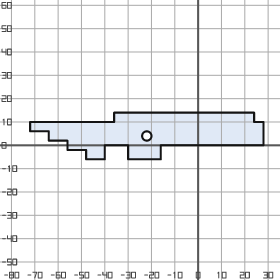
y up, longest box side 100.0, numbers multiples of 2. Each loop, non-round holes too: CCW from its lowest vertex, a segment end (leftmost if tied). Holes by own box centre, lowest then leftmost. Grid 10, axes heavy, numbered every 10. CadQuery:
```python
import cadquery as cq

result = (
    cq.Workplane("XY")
    .moveTo(-48.0, -6.0)
    .lineTo(-40.0, -6.0)
    .lineTo(-40.0, 0.0)
    .lineTo(-30.0, 0.0)
    .lineTo(-30.0, -6.0)
    .lineTo(-16.0, -6.0)
    .lineTo(-16.0, 0.0)
    .lineTo(28.0, 0.0)
    .lineTo(28.0, 10.0)
    .lineTo(24.0, 10.0)
    .lineTo(24.0, 14.0)
    .lineTo(-36.0, 14.0)
    .lineTo(-36.0, 10.0)
    .lineTo(-72.0, 10.0)
    .lineTo(-72.0, 6.0)
    .lineTo(-64.0, 6.0)
    .lineTo(-64.0, 2.0)
    .lineTo(-56.0, 2.0)
    .lineTo(-56.0, -2.0)
    .lineTo(-48.0, -2.0)
    .close()
    .moveTo(-22.0, 4.0)
    .circle(2.0)
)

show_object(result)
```